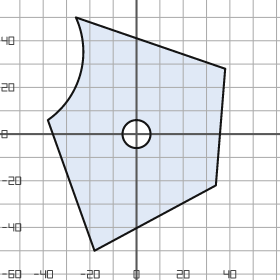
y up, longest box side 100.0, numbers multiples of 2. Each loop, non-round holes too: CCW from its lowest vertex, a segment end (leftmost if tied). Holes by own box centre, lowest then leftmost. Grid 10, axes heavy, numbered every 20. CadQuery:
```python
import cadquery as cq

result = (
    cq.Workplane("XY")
    .moveTo(-18.0, -50.0)
    .lineTo(34.0, -22.0)
    .lineTo(38.0, 28.0)
    .lineTo(-26.0, 50.0)
    .threePointArc((-24.0, 26.0), (-38.0, 6.0))
    .close()
    .moveTo(0.0, 0.0)
    .circle(6.0)
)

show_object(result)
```